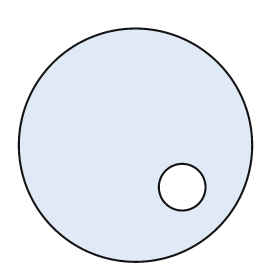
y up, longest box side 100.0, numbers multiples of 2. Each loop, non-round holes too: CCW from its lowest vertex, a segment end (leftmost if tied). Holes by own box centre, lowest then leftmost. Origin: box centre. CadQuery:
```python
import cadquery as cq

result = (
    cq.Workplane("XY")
    .moveTo(0.0, 0.0)
    .circle(50.0)
    .moveTo(20.0, -18.0)
    .circle(10.0)
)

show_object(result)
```